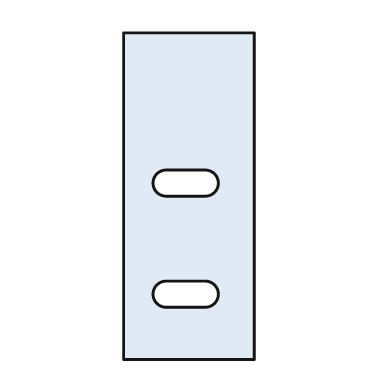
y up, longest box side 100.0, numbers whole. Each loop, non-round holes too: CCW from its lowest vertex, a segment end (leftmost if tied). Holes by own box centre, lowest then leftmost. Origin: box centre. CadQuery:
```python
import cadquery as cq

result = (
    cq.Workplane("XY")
    .moveTo(-20.0, -50.0)
    .lineTo(20.0, -50.0)
    .lineTo(20.0, 50.0)
    .lineTo(-20.0, 50.0)
    .close()
    .moveTo(-7.0, -34.0)
    .lineTo(5.0, -34.0)
    .threePointArc((9.0, -30.0), (5.0, -26.0))
    .lineTo(-7.0, -26.0)
    .threePointArc((-11.0, -30.0), (-7.0, -34.0))
    .close()
    .moveTo(-7.0, 0.0)
    .lineTo(5.0, 0.0)
    .threePointArc((9.0, 4.0), (5.0, 8.0))
    .lineTo(-7.0, 8.0)
    .threePointArc((-11.0, 4.0), (-7.0, 0.0))
    .close()
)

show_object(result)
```